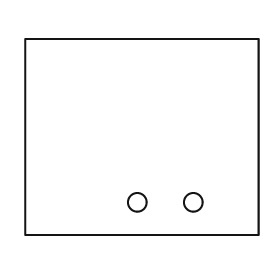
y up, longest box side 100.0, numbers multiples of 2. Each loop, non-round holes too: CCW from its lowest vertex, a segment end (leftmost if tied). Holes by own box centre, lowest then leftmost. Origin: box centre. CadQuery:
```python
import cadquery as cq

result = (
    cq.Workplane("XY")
    .moveTo(-50.0, -42.0)
    .lineTo(50.0, -42.0)
    .lineTo(50.0, 42.0)
    .lineTo(-50.0, 42.0)
    .close()
    .moveTo(-2.0, -28.0)
    .circle(4.0)
    .moveTo(22.0, -28.0)
    .circle(4.0)
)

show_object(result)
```